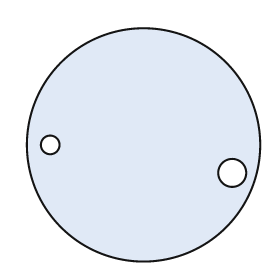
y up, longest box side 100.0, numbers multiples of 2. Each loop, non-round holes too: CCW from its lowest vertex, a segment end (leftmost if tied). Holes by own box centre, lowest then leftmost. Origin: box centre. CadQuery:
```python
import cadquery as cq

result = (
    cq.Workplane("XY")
    .moveTo(0.0, 0.0)
    .circle(50.0)
    .moveTo(38.0, -12.0)
    .circle(6.0)
    .moveTo(-40.0, 0.0)
    .circle(4.0)
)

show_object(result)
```